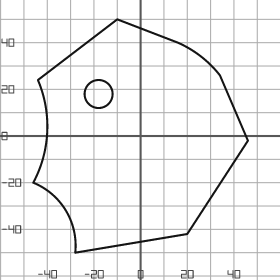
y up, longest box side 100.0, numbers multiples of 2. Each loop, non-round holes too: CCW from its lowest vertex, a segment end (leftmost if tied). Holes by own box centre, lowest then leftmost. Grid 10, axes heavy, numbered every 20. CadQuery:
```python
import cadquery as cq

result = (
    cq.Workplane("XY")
    .moveTo(-28.0, -50.0)
    .lineTo(20.0, -42.0)
    .lineTo(46.0, -2.0)
    .lineTo(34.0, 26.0)
    .threePointArc((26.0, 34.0), (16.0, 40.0))
    .lineTo(-10.0, 50.0)
    .lineTo(-44.0, 24.0)
    .threePointArc((-40.0, 2.0), (-46.0, -20.0))
    .threePointArc((-32.0, -32.0), (-28.0, -50.0))
    .close()
    .moveTo(-18.0, 18.0)
    .circle(6.0)
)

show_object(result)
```